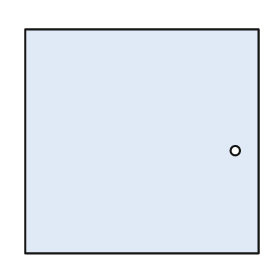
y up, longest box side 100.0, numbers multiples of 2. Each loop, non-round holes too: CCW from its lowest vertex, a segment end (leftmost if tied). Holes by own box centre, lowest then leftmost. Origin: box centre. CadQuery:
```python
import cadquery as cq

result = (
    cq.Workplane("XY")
    .moveTo(-50.0, -48.0)
    .lineTo(50.0, -48.0)
    .lineTo(50.0, 48.0)
    .lineTo(-50.0, 48.0)
    .close()
    .moveTo(40.0, -4.0)
    .circle(2.0)
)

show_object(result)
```